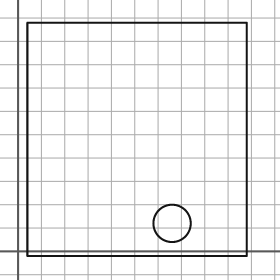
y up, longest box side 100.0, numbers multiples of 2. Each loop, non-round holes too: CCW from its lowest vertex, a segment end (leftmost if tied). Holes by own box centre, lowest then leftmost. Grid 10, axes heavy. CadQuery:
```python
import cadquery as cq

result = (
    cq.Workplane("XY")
    .moveTo(4.0, -2.0)
    .lineTo(98.0, -2.0)
    .lineTo(98.0, 98.0)
    .lineTo(4.0, 98.0)
    .close()
    .moveTo(66.0, 12.0)
    .circle(8.0)
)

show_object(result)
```